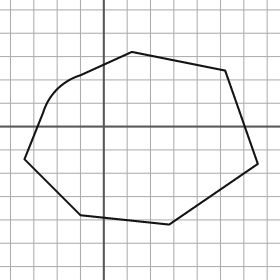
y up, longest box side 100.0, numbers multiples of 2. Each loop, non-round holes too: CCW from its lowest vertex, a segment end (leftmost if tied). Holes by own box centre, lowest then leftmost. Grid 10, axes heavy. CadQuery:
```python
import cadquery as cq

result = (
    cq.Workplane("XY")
    .moveTo(28.0, -42.0)
    .lineTo(66.0, -16.0)
    .lineTo(52.0, 24.0)
    .lineTo(12.0, 32.0)
    .lineTo(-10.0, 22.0)
    .threePointArc((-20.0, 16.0), (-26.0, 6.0))
    .lineTo(-34.0, -14.0)
    .lineTo(-10.0, -38.0)
    .close()
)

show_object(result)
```